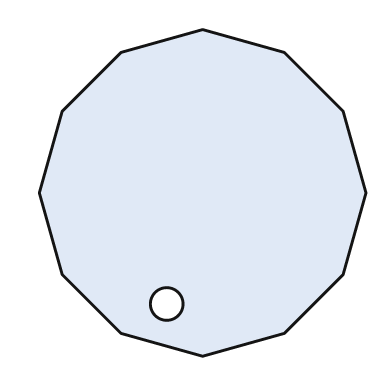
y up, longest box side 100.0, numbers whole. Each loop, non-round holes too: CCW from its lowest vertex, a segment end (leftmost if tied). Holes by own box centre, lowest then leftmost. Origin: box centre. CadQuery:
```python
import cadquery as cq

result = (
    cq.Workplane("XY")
    .moveTo(0.0, -50.0)
    .lineTo(25.0, -43.0)
    .lineTo(43.0, -25.0)
    .lineTo(50.0, 0.0)
    .lineTo(43.0, 25.0)
    .lineTo(25.0, 43.0)
    .lineTo(0.0, 50.0)
    .lineTo(-25.0, 43.0)
    .lineTo(-43.0, 25.0)
    .lineTo(-50.0, 0.0)
    .lineTo(-43.0, -25.0)
    .lineTo(-25.0, -43.0)
    .close()
    .moveTo(-11.0, -34.0)
    .circle(5.0)
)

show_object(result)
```